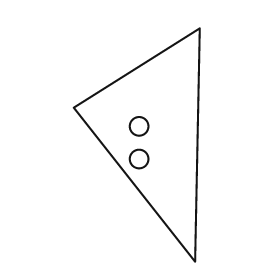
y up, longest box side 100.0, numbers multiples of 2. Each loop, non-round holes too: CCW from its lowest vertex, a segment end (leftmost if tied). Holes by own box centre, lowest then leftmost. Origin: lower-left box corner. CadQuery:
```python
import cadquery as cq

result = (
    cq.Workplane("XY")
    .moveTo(52.0, 0.0)
    .lineTo(54.0, 100.0)
    .lineTo(0.0, 66.0)
    .close()
    .moveTo(28.0, 44.0)
    .circle(4.0)
    .moveTo(28.0, 58.0)
    .circle(4.0)
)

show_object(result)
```